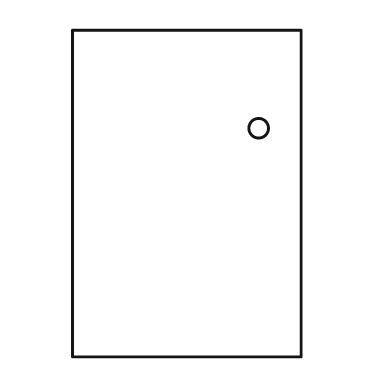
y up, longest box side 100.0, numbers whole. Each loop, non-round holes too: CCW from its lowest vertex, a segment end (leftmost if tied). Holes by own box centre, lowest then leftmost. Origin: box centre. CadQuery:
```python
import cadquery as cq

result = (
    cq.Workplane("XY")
    .moveTo(-35.0, -50.0)
    .lineTo(35.0, -50.0)
    .lineTo(35.0, 50.0)
    .lineTo(-35.0, 50.0)
    .close()
    .moveTo(22.0, 20.0)
    .circle(3.0)
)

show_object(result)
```